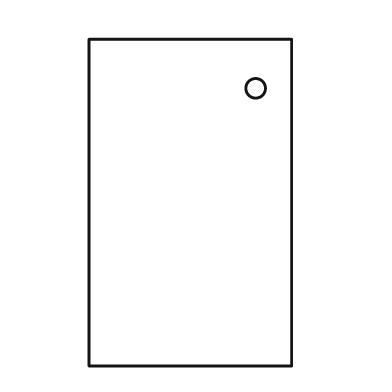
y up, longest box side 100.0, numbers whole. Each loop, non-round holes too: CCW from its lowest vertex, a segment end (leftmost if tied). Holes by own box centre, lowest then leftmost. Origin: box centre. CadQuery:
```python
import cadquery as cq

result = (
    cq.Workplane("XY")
    .moveTo(-31.0, -50.0)
    .lineTo(31.0, -50.0)
    .lineTo(31.0, 50.0)
    .lineTo(-31.0, 50.0)
    .close()
    .moveTo(20.0, 35.0)
    .circle(3.0)
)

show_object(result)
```